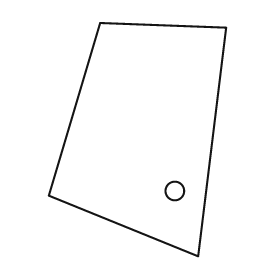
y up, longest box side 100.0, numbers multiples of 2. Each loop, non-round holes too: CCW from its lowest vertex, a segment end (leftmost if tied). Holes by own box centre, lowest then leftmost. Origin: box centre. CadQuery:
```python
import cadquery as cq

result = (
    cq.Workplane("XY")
    .moveTo(26.0, -50.0)
    .lineTo(38.0, 48.0)
    .lineTo(-16.0, 50.0)
    .lineTo(-38.0, -24.0)
    .close()
    .moveTo(16.0, -22.0)
    .circle(4.0)
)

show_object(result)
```